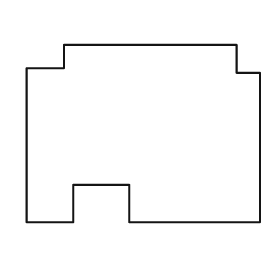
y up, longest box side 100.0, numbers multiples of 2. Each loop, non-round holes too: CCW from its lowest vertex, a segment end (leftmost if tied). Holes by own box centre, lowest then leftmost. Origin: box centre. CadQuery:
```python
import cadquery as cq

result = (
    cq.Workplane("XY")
    .moveTo(-50.0, -38.0)
    .lineTo(-30.0, -38.0)
    .lineTo(-30.0, -22.0)
    .lineTo(-6.0, -22.0)
    .lineTo(-6.0, -38.0)
    .lineTo(50.0, -38.0)
    .lineTo(50.0, 26.0)
    .lineTo(40.0, 26.0)
    .lineTo(40.0, 38.0)
    .lineTo(-34.0, 38.0)
    .lineTo(-34.0, 28.0)
    .lineTo(-50.0, 28.0)
    .close()
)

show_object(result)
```